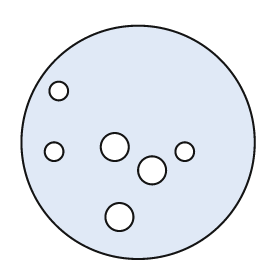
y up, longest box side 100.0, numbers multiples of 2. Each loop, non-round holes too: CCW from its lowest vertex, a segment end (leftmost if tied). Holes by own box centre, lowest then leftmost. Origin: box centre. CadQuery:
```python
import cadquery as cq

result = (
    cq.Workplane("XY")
    .moveTo(0.0, 0.0)
    .circle(50.0)
    .moveTo(-8.0, -32.0)
    .circle(6.0)
    .moveTo(6.0, -12.0)
    .circle(6.0)
    .moveTo(-36.0, -4.0)
    .circle(4.0)
    .moveTo(20.0, -4.0)
    .circle(4.0)
    .moveTo(-10.0, -2.0)
    .circle(6.0)
    .moveTo(-34.0, 22.0)
    .circle(4.0)
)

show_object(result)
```